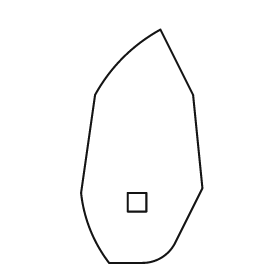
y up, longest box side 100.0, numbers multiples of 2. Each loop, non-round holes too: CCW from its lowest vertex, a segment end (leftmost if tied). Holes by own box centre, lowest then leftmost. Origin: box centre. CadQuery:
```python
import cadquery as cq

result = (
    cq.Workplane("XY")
    .moveTo(-14.0, -50.0)
    .lineTo(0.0, -50.0)
    .threePointArc((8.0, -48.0), (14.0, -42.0))
    .lineTo(26.0, -18.0)
    .lineTo(22.0, 22.0)
    .lineTo(8.0, 50.0)
    .threePointArc((-8.0, 38.0), (-20.0, 22.0))
    .lineTo(-26.0, -20.0)
    .threePointArc((-22.0, -36.0), (-14.0, -50.0))
    .close()
    .moveTo(-6.0, -28.0)
    .lineTo(2.0, -28.0)
    .lineTo(2.0, -20.0)
    .lineTo(-6.0, -20.0)
    .close()
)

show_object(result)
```